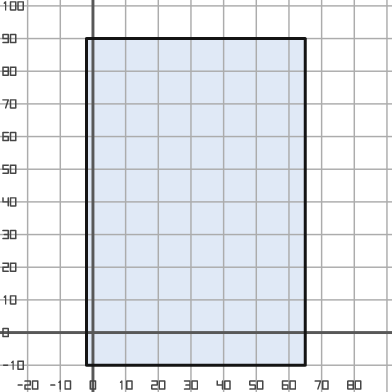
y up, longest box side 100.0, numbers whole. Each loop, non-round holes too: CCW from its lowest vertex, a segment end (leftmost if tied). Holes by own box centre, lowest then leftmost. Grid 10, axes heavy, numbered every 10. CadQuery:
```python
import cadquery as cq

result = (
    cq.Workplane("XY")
    .moveTo(-2.0, -10.0)
    .lineTo(65.0, -10.0)
    .lineTo(65.0, 90.0)
    .lineTo(-2.0, 90.0)
    .close()
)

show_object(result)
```